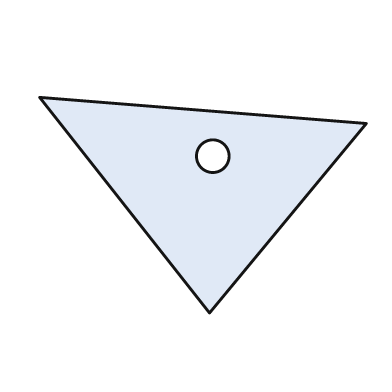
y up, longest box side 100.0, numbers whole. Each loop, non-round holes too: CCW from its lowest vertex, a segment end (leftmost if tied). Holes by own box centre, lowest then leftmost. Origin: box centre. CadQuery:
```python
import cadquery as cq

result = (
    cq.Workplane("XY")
    .moveTo(2.0, -33.0)
    .lineTo(50.0, 25.0)
    .lineTo(-50.0, 33.0)
    .close()
    .moveTo(3.0, 15.0)
    .circle(5.0)
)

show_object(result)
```